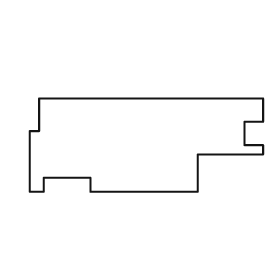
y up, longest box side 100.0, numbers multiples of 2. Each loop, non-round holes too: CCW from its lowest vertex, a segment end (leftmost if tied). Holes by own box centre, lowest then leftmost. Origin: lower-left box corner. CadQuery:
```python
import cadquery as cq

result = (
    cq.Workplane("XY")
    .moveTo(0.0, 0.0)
    .lineTo(6.0, 0.0)
    .lineTo(6.0, 6.0)
    .lineTo(26.0, 6.0)
    .lineTo(26.0, 0.0)
    .lineTo(72.0, 0.0)
    .lineTo(72.0, 16.0)
    .lineTo(100.0, 16.0)
    .lineTo(100.0, 20.0)
    .lineTo(92.0, 20.0)
    .lineTo(92.0, 30.0)
    .lineTo(100.0, 30.0)
    .lineTo(100.0, 40.0)
    .lineTo(4.0, 40.0)
    .lineTo(4.0, 26.0)
    .lineTo(0.0, 26.0)
    .close()
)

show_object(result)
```